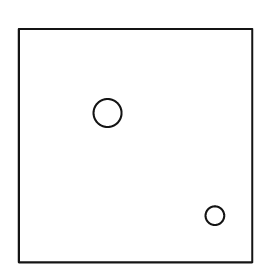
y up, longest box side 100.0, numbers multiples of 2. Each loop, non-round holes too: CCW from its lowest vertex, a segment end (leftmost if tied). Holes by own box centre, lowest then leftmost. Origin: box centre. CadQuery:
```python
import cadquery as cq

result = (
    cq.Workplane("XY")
    .moveTo(-50.0, -50.0)
    .lineTo(50.0, -50.0)
    .lineTo(50.0, 50.0)
    .lineTo(-50.0, 50.0)
    .close()
    .moveTo(34.0, -30.0)
    .circle(4.0)
    .moveTo(-12.0, 14.0)
    .circle(6.0)
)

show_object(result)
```